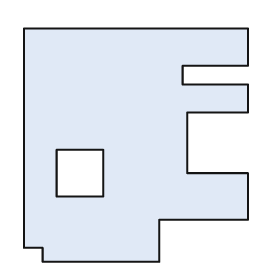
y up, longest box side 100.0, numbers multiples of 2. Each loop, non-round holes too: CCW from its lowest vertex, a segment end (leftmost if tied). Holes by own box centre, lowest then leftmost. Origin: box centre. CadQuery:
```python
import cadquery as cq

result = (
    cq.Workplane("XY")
    .moveTo(-40.0, -50.0)
    .lineTo(10.0, -50.0)
    .lineTo(10.0, -32.0)
    .lineTo(48.0, -32.0)
    .lineTo(48.0, -12.0)
    .lineTo(22.0, -12.0)
    .lineTo(22.0, 14.0)
    .lineTo(48.0, 14.0)
    .lineTo(48.0, 26.0)
    .lineTo(20.0, 26.0)
    .lineTo(20.0, 34.0)
    .lineTo(48.0, 34.0)
    .lineTo(48.0, 50.0)
    .lineTo(-48.0, 50.0)
    .lineTo(-48.0, -44.0)
    .lineTo(-40.0, -44.0)
    .close()
    .moveTo(-34.0, -22.0)
    .lineTo(-14.0, -22.0)
    .lineTo(-14.0, -2.0)
    .lineTo(-34.0, -2.0)
    .close()
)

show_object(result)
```